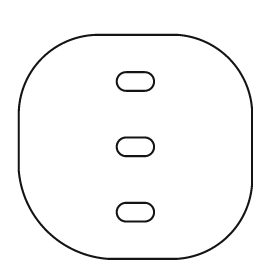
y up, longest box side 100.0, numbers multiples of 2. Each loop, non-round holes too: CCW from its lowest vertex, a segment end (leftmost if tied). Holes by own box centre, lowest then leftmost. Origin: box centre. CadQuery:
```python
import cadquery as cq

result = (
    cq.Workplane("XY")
    .moveTo(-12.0, -48.0)
    .lineTo(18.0, -48.0)
    .threePointArc((40.0, -38.0), (50.0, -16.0))
    .lineTo(50.0, 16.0)
    .threePointArc((40.0, 38.0), (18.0, 48.0))
    .lineTo(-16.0, 48.0)
    .threePointArc((-40.0, 38.0), (-50.0, 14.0))
    .lineTo(-50.0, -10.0)
    .threePointArc((-38.0, -36.0), (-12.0, -48.0))
    .close()
    .moveTo(-4.0, -32.0)
    .lineTo(4.0, -32.0)
    .threePointArc((8.0, -28.0), (4.0, -24.0))
    .lineTo(-4.0, -24.0)
    .threePointArc((-8.0, -28.0), (-4.0, -32.0))
    .close()
    .moveTo(-4.0, -4.0)
    .lineTo(4.0, -4.0)
    .threePointArc((8.0, 0.0), (4.0, 4.0))
    .lineTo(-4.0, 4.0)
    .threePointArc((-8.0, 0.0), (-4.0, -4.0))
    .close()
    .moveTo(-4.0, 24.0)
    .lineTo(4.0, 24.0)
    .threePointArc((8.0, 28.0), (4.0, 32.0))
    .lineTo(-4.0, 32.0)
    .threePointArc((-8.0, 28.0), (-4.0, 24.0))
    .close()
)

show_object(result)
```